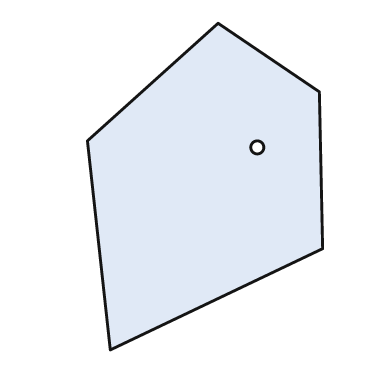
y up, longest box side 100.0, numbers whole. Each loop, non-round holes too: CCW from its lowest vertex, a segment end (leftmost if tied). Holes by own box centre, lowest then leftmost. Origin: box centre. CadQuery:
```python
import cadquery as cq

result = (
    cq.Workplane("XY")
    .moveTo(-29.0, -50.0)
    .lineTo(36.0, -19.0)
    .lineTo(35.0, 29.0)
    .lineTo(4.0, 50.0)
    .lineTo(-36.0, 14.0)
    .close()
    .moveTo(16.0, 12.0)
    .circle(2.0)
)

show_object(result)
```